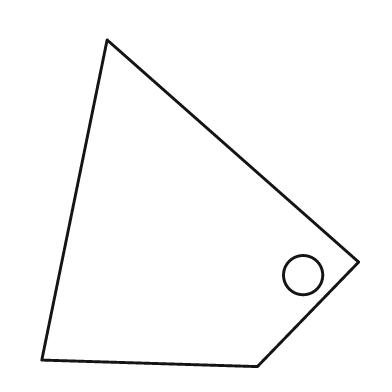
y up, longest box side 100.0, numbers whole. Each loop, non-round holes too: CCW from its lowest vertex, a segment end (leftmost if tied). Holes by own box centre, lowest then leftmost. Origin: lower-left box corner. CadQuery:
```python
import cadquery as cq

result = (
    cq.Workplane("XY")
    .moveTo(66.0, 0.0)
    .lineTo(97.0, 32.0)
    .lineTo(20.0, 100.0)
    .lineTo(0.0, 2.0)
    .close()
    .moveTo(80.0, 28.0)
    .circle(6.0)
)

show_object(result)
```